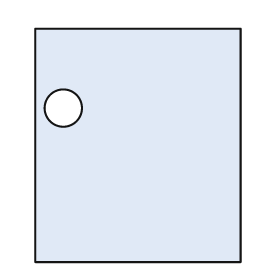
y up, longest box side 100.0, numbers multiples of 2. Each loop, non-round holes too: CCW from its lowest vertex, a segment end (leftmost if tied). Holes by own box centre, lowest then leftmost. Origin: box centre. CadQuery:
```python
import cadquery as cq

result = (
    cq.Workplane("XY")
    .moveTo(-44.0, -50.0)
    .lineTo(44.0, -50.0)
    .lineTo(44.0, 50.0)
    .lineTo(-44.0, 50.0)
    .close()
    .moveTo(-32.0, 16.0)
    .circle(8.0)
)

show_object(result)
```